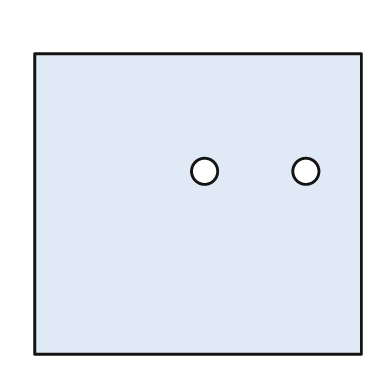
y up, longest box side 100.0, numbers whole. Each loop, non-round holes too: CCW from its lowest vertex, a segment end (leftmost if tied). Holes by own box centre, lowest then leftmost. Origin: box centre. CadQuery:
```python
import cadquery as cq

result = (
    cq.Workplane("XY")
    .moveTo(-50.0, -46.0)
    .lineTo(50.0, -46.0)
    .lineTo(50.0, 46.0)
    .lineTo(-50.0, 46.0)
    .close()
    .moveTo(2.0, 10.0)
    .circle(4.0)
    .moveTo(33.0, 10.0)
    .circle(4.0)
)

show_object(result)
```